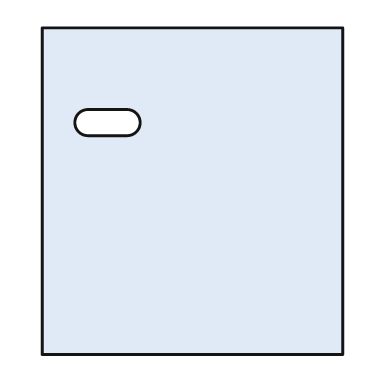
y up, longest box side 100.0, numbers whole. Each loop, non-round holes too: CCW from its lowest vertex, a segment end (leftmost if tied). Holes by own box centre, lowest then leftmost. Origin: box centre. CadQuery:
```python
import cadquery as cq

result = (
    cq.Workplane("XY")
    .moveTo(-46.0, -50.0)
    .lineTo(46.0, -50.0)
    .lineTo(46.0, 50.0)
    .lineTo(-46.0, 50.0)
    .close()
    .moveTo(-32.0, 17.0)
    .lineTo(-20.0, 17.0)
    .threePointArc((-16.0, 21.0), (-20.0, 25.0))
    .lineTo(-32.0, 25.0)
    .threePointArc((-36.0, 21.0), (-32.0, 17.0))
    .close()
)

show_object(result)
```